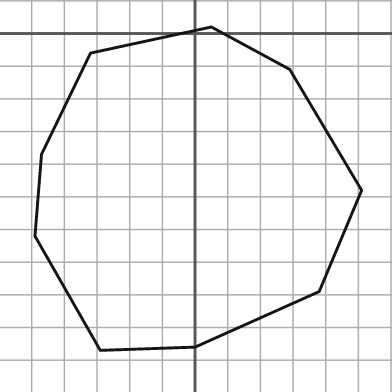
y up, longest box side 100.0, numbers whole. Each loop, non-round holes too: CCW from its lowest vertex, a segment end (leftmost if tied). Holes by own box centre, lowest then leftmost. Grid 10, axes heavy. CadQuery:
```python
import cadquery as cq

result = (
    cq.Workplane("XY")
    .moveTo(-29.0, -97.0)
    .lineTo(0.0, -96.0)
    .lineTo(38.0, -79.0)
    .lineTo(51.0, -48.0)
    .lineTo(29.0, -11.0)
    .lineTo(5.0, 2.0)
    .lineTo(-32.0, -6.0)
    .lineTo(-47.0, -37.0)
    .lineTo(-49.0, -62.0)
    .close()
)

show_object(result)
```